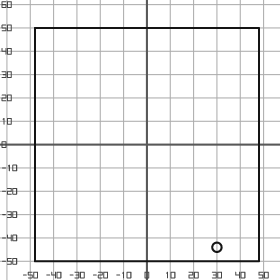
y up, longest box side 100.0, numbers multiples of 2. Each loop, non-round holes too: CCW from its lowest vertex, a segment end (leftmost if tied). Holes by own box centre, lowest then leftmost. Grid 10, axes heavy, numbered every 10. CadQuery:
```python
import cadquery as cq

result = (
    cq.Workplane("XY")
    .moveTo(-48.0, -50.0)
    .lineTo(48.0, -50.0)
    .lineTo(48.0, 50.0)
    .lineTo(-48.0, 50.0)
    .close()
    .moveTo(30.0, -44.0)
    .circle(2.0)
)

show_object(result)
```